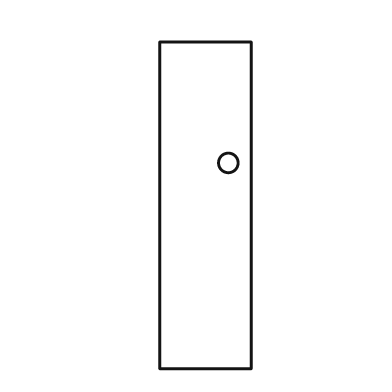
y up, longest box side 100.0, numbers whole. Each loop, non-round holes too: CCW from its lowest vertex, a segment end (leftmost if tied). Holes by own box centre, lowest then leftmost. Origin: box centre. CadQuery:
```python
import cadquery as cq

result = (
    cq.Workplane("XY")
    .moveTo(-14.0, -50.0)
    .lineTo(14.0, -50.0)
    .lineTo(14.0, 50.0)
    .lineTo(-14.0, 50.0)
    .close()
    .moveTo(7.0, 13.0)
    .circle(3.0)
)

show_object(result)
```